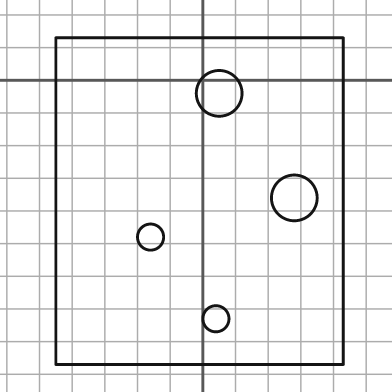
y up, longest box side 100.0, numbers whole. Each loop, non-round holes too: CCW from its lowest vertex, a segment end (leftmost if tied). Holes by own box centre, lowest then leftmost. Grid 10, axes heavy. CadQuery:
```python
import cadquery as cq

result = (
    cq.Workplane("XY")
    .moveTo(-45.0, -87.0)
    .lineTo(43.0, -87.0)
    .lineTo(43.0, 13.0)
    .lineTo(-45.0, 13.0)
    .close()
    .moveTo(4.0, -73.0)
    .circle(4.0)
    .moveTo(-16.0, -48.0)
    .circle(4.0)
    .moveTo(28.0, -36.0)
    .circle(7.0)
    .moveTo(5.0, -4.0)
    .circle(7.0)
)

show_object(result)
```